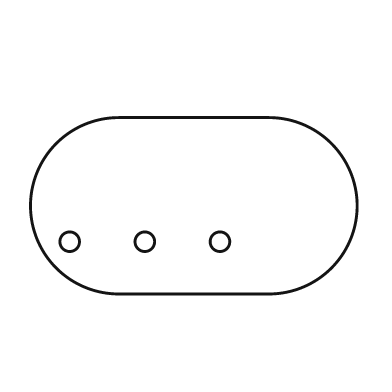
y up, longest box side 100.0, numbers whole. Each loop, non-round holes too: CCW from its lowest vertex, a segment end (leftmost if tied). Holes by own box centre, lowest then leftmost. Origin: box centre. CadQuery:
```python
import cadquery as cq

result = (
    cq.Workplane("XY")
    .moveTo(-23.0, -27.0)
    .lineTo(23.0, -27.0)
    .threePointArc((50.0, 0.0), (23.0, 27.0))
    .lineTo(-23.0, 27.0)
    .threePointArc((-50.0, 0.0), (-23.0, -27.0))
    .close()
    .moveTo(-38.0, -11.0)
    .circle(3.0)
    .moveTo(-15.0, -11.0)
    .circle(3.0)
    .moveTo(8.0, -11.0)
    .circle(3.0)
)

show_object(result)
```